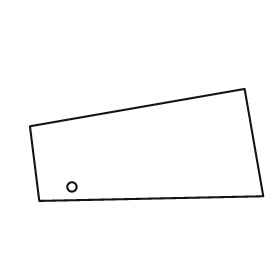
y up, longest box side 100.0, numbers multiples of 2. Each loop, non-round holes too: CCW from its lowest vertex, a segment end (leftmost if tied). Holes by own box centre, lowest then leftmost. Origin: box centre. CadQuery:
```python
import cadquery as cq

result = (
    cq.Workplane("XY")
    .moveTo(-46.0, -24.0)
    .lineTo(50.0, -22.0)
    .lineTo(42.0, 24.0)
    .lineTo(-50.0, 8.0)
    .close()
    .moveTo(-32.0, -18.0)
    .circle(2.0)
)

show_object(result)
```